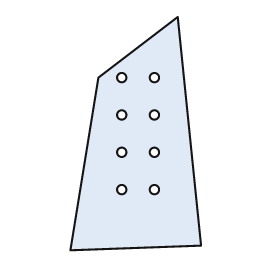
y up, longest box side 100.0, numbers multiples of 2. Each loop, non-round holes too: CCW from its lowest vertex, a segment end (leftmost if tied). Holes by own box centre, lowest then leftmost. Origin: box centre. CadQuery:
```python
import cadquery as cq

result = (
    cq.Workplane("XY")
    .moveTo(-28.0, -50.0)
    .lineTo(28.0, -48.0)
    .lineTo(18.0, 50.0)
    .lineTo(-16.0, 24.0)
    .close()
    .moveTo(-6.0, -24.0)
    .circle(2.0)
    .moveTo(8.0, -24.0)
    .circle(2.0)
    .moveTo(-6.0, -8.0)
    .circle(2.0)
    .moveTo(8.0, -8.0)
    .circle(2.0)
    .moveTo(-6.0, 8.0)
    .circle(2.0)
    .moveTo(8.0, 8.0)
    .circle(2.0)
    .moveTo(-6.0, 24.0)
    .circle(2.0)
    .moveTo(8.0, 24.0)
    .circle(2.0)
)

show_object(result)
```